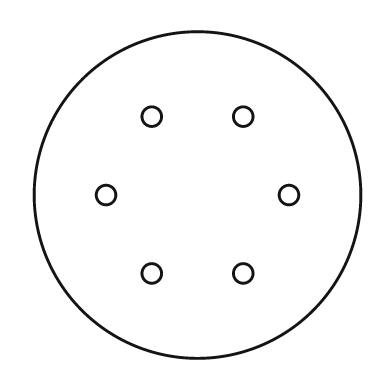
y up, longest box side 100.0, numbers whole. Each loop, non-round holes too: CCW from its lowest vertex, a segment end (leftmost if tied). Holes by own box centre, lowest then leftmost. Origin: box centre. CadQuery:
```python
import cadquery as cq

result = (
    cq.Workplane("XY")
    .moveTo(0.0, 0.0)
    .circle(50.0)
    .moveTo(-14.0, -24.0)
    .circle(3.0)
    .moveTo(14.0, -24.0)
    .circle(3.0)
    .moveTo(-28.0, 0.0)
    .circle(3.0)
    .moveTo(28.0, 0.0)
    .circle(3.0)
    .moveTo(-14.0, 24.0)
    .circle(3.0)
    .moveTo(14.0, 24.0)
    .circle(3.0)
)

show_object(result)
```